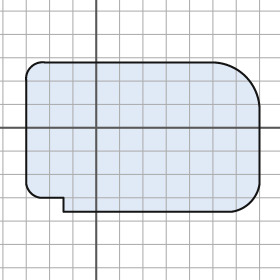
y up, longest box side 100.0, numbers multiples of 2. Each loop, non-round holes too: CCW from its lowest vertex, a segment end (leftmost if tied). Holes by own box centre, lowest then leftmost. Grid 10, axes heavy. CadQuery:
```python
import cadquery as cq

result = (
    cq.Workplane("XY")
    .moveTo(-14.0, -36.0)
    .lineTo(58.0, -36.0)
    .threePointArc((66.0, -32.0), (70.0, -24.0))
    .lineTo(70.0, 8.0)
    .threePointArc((64.0, 22.0), (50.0, 28.0))
    .lineTo(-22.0, 28.0)
    .threePointArc((-28.0, 26.0), (-30.0, 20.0))
    .lineTo(-30.0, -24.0)
    .threePointArc((-28.0, -28.0), (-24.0, -30.0))
    .lineTo(-14.0, -30.0)
    .close()
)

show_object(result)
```